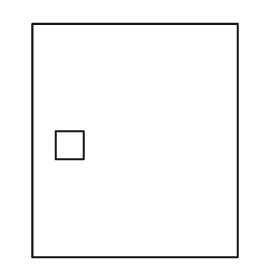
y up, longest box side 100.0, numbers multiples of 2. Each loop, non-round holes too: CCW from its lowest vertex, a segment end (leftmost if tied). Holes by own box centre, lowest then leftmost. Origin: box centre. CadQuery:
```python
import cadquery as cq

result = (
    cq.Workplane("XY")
    .moveTo(-44.0, -50.0)
    .lineTo(44.0, -50.0)
    .lineTo(44.0, 50.0)
    .lineTo(-44.0, 50.0)
    .close()
    .moveTo(-34.0, -8.0)
    .lineTo(-22.0, -8.0)
    .lineTo(-22.0, 4.0)
    .lineTo(-34.0, 4.0)
    .close()
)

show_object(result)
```